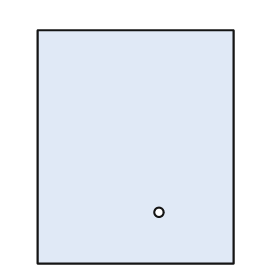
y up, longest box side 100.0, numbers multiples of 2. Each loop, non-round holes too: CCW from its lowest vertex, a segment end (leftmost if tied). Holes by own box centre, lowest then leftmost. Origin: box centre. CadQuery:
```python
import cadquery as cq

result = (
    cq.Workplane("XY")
    .moveTo(-42.0, -50.0)
    .lineTo(42.0, -50.0)
    .lineTo(42.0, 50.0)
    .lineTo(-42.0, 50.0)
    .close()
    .moveTo(10.0, -28.0)
    .circle(2.0)
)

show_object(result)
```